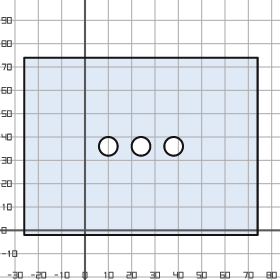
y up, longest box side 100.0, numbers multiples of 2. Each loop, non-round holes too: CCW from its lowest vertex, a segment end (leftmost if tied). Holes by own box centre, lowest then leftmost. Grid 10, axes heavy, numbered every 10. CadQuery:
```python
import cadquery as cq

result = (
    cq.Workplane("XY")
    .moveTo(-26.0, -2.0)
    .lineTo(74.0, -2.0)
    .lineTo(74.0, 74.0)
    .lineTo(-26.0, 74.0)
    .close()
    .moveTo(10.0, 36.0)
    .circle(4.0)
    .moveTo(24.0, 36.0)
    .circle(4.0)
    .moveTo(38.0, 36.0)
    .circle(4.0)
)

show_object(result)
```